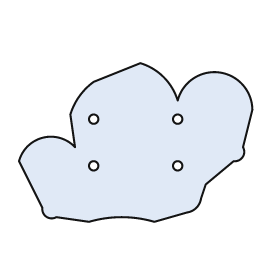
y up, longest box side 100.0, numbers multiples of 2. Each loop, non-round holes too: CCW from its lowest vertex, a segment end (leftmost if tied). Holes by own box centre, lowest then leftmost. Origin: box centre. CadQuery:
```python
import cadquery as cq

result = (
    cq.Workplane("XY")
    .moveTo(-20.0, -34.0)
    .threePointArc((-6.0, -32.0), (8.0, -34.0))
    .lineTo(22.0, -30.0)
    .threePointArc((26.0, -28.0), (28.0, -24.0))
    .lineTo(30.0, -18.0)
    .lineTo(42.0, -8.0)
    .threePointArc((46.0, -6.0), (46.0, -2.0))
    .lineTo(50.0, 14.0)
    .threePointArc((36.0, 30.0), (18.0, 18.0))
    .threePointArc((12.0, 28.0), (2.0, 34.0))
    .lineTo(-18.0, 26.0)
    .threePointArc((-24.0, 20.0), (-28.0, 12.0))
    .lineTo(-26.0, -2.0)
    .threePointArc((-40.0, 2.0), (-50.0, -8.0))
    .lineTo(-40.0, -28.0)
    .threePointArc((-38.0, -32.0), (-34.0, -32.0))
    .close()
    .moveTo(-18.0, -10.0)
    .circle(2.0)
    .moveTo(18.0, -10.0)
    .circle(2.0)
    .moveTo(-18.0, 10.0)
    .circle(2.0)
    .moveTo(18.0, 10.0)
    .circle(2.0)
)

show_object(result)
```